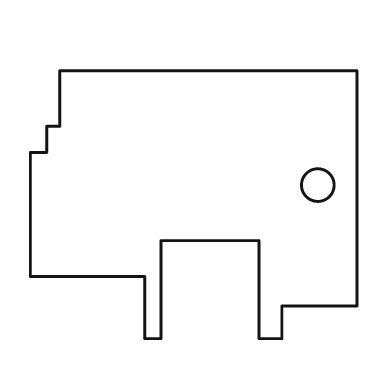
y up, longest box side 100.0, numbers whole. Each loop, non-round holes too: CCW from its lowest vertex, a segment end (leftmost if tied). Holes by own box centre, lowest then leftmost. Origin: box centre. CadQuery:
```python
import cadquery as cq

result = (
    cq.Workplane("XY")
    .moveTo(-15.0, -41.0)
    .lineTo(-10.0, -41.0)
    .lineTo(-10.0, -11.0)
    .lineTo(20.0, -11.0)
    .lineTo(20.0, -41.0)
    .lineTo(27.0, -41.0)
    .lineTo(27.0, -31.0)
    .lineTo(50.0, -31.0)
    .lineTo(50.0, 41.0)
    .lineTo(-41.0, 41.0)
    .lineTo(-41.0, 24.0)
    .lineTo(-45.0, 24.0)
    .lineTo(-45.0, 16.0)
    .lineTo(-50.0, 16.0)
    .lineTo(-50.0, -22.0)
    .lineTo(-15.0, -22.0)
    .close()
    .moveTo(38.0, 6.0)
    .circle(5.0)
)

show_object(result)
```